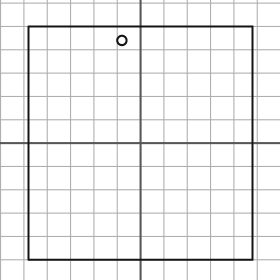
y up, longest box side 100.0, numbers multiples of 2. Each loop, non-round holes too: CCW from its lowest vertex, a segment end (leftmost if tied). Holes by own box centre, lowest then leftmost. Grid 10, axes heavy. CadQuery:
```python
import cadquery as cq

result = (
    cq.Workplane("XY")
    .moveTo(-48.0, -50.0)
    .lineTo(48.0, -50.0)
    .lineTo(48.0, 50.0)
    .lineTo(-48.0, 50.0)
    .close()
    .moveTo(-8.0, 44.0)
    .circle(2.0)
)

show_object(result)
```